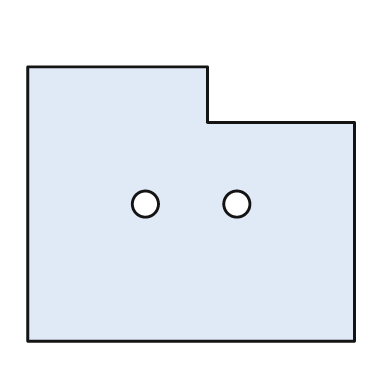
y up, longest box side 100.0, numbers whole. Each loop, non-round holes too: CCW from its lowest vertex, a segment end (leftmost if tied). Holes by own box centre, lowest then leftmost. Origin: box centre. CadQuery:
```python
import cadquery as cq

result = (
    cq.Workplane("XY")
    .moveTo(-50.0, -42.0)
    .lineTo(50.0, -42.0)
    .lineTo(50.0, 25.0)
    .lineTo(5.0, 25.0)
    .lineTo(5.0, 42.0)
    .lineTo(-50.0, 42.0)
    .close()
    .moveTo(-14.0, 0.0)
    .circle(4.0)
    .moveTo(14.0, 0.0)
    .circle(4.0)
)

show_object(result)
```